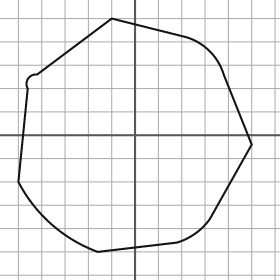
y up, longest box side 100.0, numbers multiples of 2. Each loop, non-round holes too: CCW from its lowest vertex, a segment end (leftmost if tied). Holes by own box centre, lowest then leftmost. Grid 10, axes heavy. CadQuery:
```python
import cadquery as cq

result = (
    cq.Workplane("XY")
    .moveTo(-16.0, -50.0)
    .lineTo(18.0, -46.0)
    .threePointArc((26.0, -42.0), (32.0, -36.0))
    .lineTo(50.0, -4.0)
    .lineTo(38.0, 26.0)
    .threePointArc((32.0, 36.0), (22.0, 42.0))
    .lineTo(-10.0, 50.0)
    .lineTo(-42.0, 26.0)
    .threePointArc((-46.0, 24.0), (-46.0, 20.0))
    .lineTo(-50.0, -20.0)
    .threePointArc((-36.0, -38.0), (-16.0, -50.0))
    .close()
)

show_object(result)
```